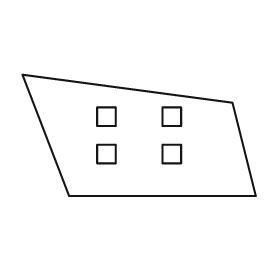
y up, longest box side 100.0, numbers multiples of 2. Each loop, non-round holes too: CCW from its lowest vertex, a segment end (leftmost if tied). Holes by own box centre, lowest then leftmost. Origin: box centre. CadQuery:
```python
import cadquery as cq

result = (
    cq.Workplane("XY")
    .moveTo(-30.0, -26.0)
    .lineTo(50.0, -26.0)
    .lineTo(40.0, 14.0)
    .lineTo(-50.0, 26.0)
    .close()
    .moveTo(-18.0, -12.0)
    .lineTo(-10.0, -12.0)
    .lineTo(-10.0, -4.0)
    .lineTo(-18.0, -4.0)
    .close()
    .moveTo(10.0, -12.0)
    .lineTo(18.0, -12.0)
    .lineTo(18.0, -4.0)
    .lineTo(10.0, -4.0)
    .close()
    .moveTo(-18.0, 4.0)
    .lineTo(-10.0, 4.0)
    .lineTo(-10.0, 12.0)
    .lineTo(-18.0, 12.0)
    .close()
    .moveTo(10.0, 4.0)
    .lineTo(18.0, 4.0)
    .lineTo(18.0, 12.0)
    .lineTo(10.0, 12.0)
    .close()
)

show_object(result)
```